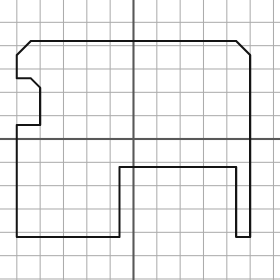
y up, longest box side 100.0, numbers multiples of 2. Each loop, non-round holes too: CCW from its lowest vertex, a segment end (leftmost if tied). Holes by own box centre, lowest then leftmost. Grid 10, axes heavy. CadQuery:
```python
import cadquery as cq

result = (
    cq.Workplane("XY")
    .moveTo(-50.0, -42.0)
    .lineTo(-6.0, -42.0)
    .lineTo(-6.0, -12.0)
    .lineTo(44.0, -12.0)
    .lineTo(44.0, -42.0)
    .lineTo(50.0, -42.0)
    .lineTo(50.0, 36.0)
    .lineTo(44.0, 42.0)
    .lineTo(-44.0, 42.0)
    .lineTo(-50.0, 36.0)
    .lineTo(-50.0, 26.0)
    .lineTo(-44.0, 26.0)
    .lineTo(-40.0, 22.0)
    .lineTo(-40.0, 6.0)
    .lineTo(-50.0, 6.0)
    .close()
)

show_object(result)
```